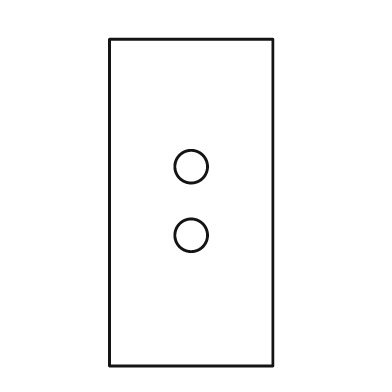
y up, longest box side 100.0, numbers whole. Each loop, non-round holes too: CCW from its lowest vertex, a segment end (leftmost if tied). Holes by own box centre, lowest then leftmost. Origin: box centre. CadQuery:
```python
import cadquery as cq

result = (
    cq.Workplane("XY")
    .moveTo(-25.0, -50.0)
    .lineTo(25.0, -50.0)
    .lineTo(25.0, 50.0)
    .lineTo(-25.0, 50.0)
    .close()
    .moveTo(0.0, -10.0)
    .circle(5.0)
    .moveTo(0.0, 11.0)
    .circle(5.0)
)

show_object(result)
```